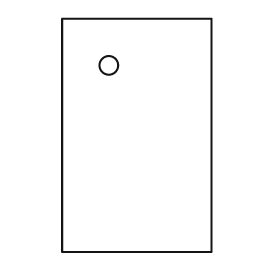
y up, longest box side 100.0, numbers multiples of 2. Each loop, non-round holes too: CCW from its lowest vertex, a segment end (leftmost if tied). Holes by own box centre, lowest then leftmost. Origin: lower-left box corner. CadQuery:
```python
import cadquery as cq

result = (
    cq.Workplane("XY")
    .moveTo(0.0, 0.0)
    .lineTo(64.0, 0.0)
    .lineTo(64.0, 100.0)
    .lineTo(0.0, 100.0)
    .close()
    .moveTo(20.0, 80.0)
    .circle(4.0)
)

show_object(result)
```